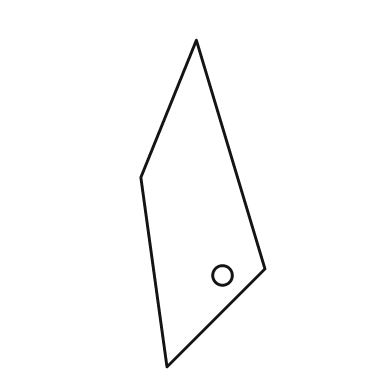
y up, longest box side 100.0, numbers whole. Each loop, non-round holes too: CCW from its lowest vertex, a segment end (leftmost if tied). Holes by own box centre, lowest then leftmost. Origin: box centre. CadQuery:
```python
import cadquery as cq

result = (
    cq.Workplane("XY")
    .moveTo(-11.0, -50.0)
    .lineTo(19.0, -20.0)
    .lineTo(-2.0, 50.0)
    .lineTo(-19.0, 8.0)
    .close()
    .moveTo(6.0, -22.0)
    .circle(3.0)
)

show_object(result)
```